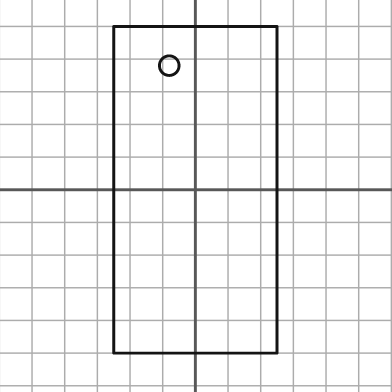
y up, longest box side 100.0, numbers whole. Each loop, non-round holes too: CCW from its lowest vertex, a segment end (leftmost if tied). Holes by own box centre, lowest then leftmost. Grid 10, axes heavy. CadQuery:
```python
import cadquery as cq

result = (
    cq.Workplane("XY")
    .moveTo(-25.0, -50.0)
    .lineTo(25.0, -50.0)
    .lineTo(25.0, 50.0)
    .lineTo(-25.0, 50.0)
    .close()
    .moveTo(-8.0, 38.0)
    .circle(3.0)
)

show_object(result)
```